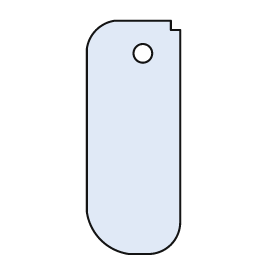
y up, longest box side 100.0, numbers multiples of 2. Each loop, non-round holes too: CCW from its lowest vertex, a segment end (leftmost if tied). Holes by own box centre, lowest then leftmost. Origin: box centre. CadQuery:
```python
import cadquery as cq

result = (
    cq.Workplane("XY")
    .moveTo(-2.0, -50.0)
    .lineTo(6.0, -50.0)
    .threePointArc((16.0, -46.0), (20.0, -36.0))
    .lineTo(20.0, 46.0)
    .lineTo(16.0, 46.0)
    .lineTo(16.0, 50.0)
    .lineTo(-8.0, 50.0)
    .threePointArc((-16.0, 46.0), (-20.0, 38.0))
    .lineTo(-20.0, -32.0)
    .threePointArc((-14.0, -44.0), (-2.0, -50.0))
    .close()
    .moveTo(4.0, 36.0)
    .circle(4.0)
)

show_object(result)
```